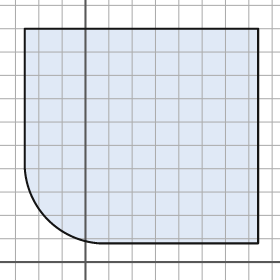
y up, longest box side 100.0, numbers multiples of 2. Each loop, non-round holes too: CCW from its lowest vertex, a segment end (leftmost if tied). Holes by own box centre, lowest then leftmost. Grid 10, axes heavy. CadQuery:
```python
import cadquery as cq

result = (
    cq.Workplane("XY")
    .moveTo(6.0, 8.0)
    .lineTo(74.0, 8.0)
    .lineTo(74.0, 100.0)
    .lineTo(-26.0, 100.0)
    .lineTo(-26.0, 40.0)
    .threePointArc((-16.0, 18.0), (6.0, 8.0))
    .close()
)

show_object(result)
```